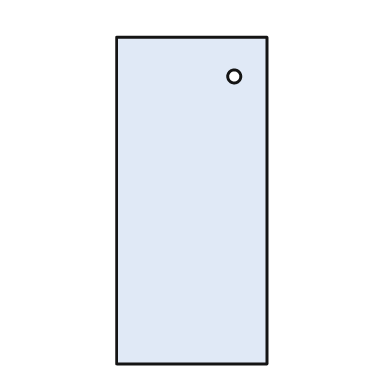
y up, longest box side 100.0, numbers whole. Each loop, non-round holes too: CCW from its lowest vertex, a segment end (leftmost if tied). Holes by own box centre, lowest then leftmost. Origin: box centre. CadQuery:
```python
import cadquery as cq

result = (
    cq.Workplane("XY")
    .moveTo(-23.0, -50.0)
    .lineTo(23.0, -50.0)
    .lineTo(23.0, 50.0)
    .lineTo(-23.0, 50.0)
    .close()
    .moveTo(13.0, 38.0)
    .circle(2.0)
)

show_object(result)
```